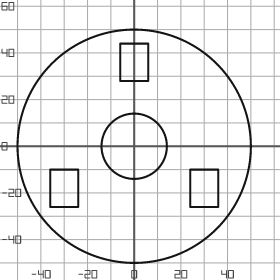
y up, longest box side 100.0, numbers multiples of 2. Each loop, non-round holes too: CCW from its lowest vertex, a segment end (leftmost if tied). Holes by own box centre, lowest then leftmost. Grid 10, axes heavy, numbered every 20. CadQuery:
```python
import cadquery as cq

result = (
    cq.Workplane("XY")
    .moveTo(0.0, 0.0)
    .circle(50.0)
    .moveTo(-36.0, -26.0)
    .lineTo(-24.0, -26.0)
    .lineTo(-24.0, -10.0)
    .lineTo(-36.0, -10.0)
    .close()
    .moveTo(24.0, -26.0)
    .lineTo(36.0, -26.0)
    .lineTo(36.0, -10.0)
    .lineTo(24.0, -10.0)
    .close()
    .moveTo(0.0, 0.0)
    .circle(14.0)
    .moveTo(-6.0, 28.0)
    .lineTo(6.0, 28.0)
    .lineTo(6.0, 44.0)
    .lineTo(-6.0, 44.0)
    .close()
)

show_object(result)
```